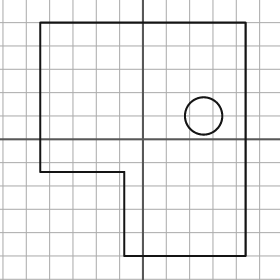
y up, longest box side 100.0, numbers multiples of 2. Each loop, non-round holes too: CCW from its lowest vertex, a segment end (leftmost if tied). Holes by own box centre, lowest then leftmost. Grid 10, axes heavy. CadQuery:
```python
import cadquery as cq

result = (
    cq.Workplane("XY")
    .moveTo(-8.0, -50.0)
    .lineTo(44.0, -50.0)
    .lineTo(44.0, 50.0)
    .lineTo(-44.0, 50.0)
    .lineTo(-44.0, -14.0)
    .lineTo(-8.0, -14.0)
    .close()
    .moveTo(26.0, 10.0)
    .circle(8.0)
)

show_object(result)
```